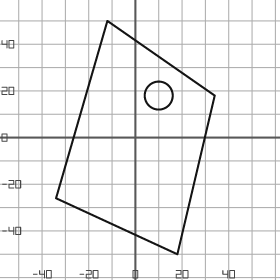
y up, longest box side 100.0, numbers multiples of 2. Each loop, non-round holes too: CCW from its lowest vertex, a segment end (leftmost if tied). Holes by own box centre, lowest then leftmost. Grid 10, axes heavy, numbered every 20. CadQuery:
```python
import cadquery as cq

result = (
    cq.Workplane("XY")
    .moveTo(18.0, -50.0)
    .lineTo(34.0, 18.0)
    .lineTo(-12.0, 50.0)
    .lineTo(-34.0, -26.0)
    .close()
    .moveTo(10.0, 18.0)
    .circle(6.0)
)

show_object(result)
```